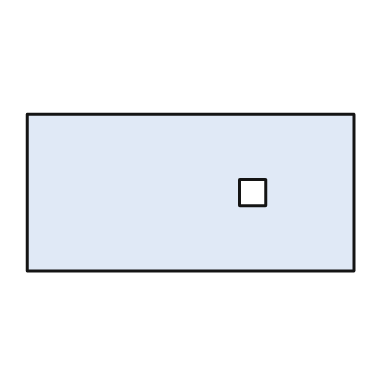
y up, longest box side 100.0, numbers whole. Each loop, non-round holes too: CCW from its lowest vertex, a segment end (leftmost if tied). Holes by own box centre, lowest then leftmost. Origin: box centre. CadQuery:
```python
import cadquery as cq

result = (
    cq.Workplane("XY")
    .moveTo(-50.0, -24.0)
    .lineTo(50.0, -24.0)
    .lineTo(50.0, 24.0)
    .lineTo(-50.0, 24.0)
    .close()
    .moveTo(15.0, -4.0)
    .lineTo(23.0, -4.0)
    .lineTo(23.0, 4.0)
    .lineTo(15.0, 4.0)
    .close()
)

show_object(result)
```